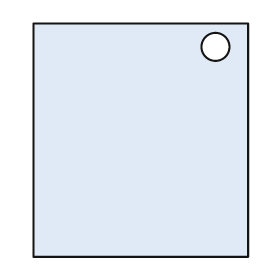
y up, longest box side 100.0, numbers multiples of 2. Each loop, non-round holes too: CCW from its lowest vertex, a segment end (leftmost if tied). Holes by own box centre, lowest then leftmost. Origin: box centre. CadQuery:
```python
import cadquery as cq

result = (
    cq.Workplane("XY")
    .moveTo(-46.0, -50.0)
    .lineTo(46.0, -50.0)
    .lineTo(46.0, 50.0)
    .lineTo(-46.0, 50.0)
    .close()
    .moveTo(32.0, 40.0)
    .circle(6.0)
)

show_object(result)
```